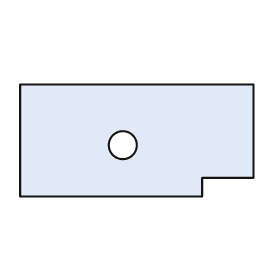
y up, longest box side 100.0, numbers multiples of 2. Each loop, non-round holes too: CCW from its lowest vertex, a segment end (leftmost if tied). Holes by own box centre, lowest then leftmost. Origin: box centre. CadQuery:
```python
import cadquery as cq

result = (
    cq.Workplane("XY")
    .moveTo(-50.0, -24.0)
    .lineTo(28.0, -24.0)
    .lineTo(28.0, -16.0)
    .lineTo(50.0, -16.0)
    .lineTo(50.0, 24.0)
    .lineTo(-50.0, 24.0)
    .close()
    .moveTo(-6.0, -2.0)
    .circle(6.0)
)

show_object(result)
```